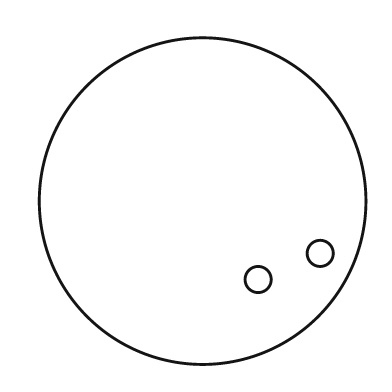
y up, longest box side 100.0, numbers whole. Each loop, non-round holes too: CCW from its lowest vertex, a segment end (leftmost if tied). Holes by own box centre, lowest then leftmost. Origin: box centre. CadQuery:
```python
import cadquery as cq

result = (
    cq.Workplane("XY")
    .moveTo(0.0, 0.0)
    .circle(50.0)
    .moveTo(17.0, -24.0)
    .circle(4.0)
    .moveTo(36.0, -16.0)
    .circle(4.0)
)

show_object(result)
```